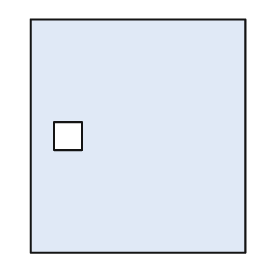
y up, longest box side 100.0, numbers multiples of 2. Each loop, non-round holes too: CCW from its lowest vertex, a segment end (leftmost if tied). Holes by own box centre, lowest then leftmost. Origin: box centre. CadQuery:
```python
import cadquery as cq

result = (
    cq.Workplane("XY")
    .moveTo(-46.0, -50.0)
    .lineTo(46.0, -50.0)
    .lineTo(46.0, 50.0)
    .lineTo(-46.0, 50.0)
    .close()
    .moveTo(-36.0, -6.0)
    .lineTo(-24.0, -6.0)
    .lineTo(-24.0, 6.0)
    .lineTo(-36.0, 6.0)
    .close()
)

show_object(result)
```